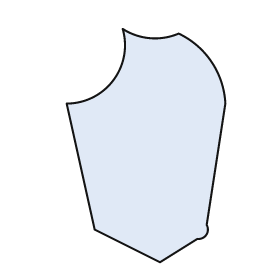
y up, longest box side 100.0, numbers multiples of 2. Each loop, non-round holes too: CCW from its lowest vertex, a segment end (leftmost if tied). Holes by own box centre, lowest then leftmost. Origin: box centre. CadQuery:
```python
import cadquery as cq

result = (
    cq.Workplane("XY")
    .moveTo(6.0, -50.0)
    .lineTo(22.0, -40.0)
    .threePointArc((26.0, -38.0), (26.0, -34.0))
    .lineTo(34.0, 18.0)
    .threePointArc((28.0, 36.0), (14.0, 48.0))
    .threePointArc((2.0, 46.0), (-10.0, 50.0))
    .threePointArc((-14.0, 28.0), (-34.0, 18.0))
    .lineTo(-22.0, -36.0)
    .close()
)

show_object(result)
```